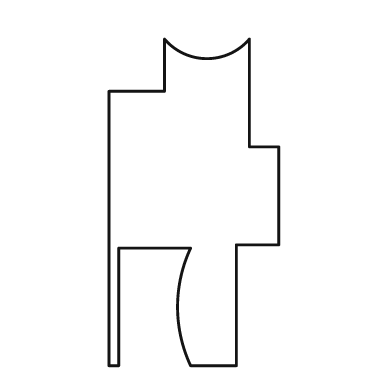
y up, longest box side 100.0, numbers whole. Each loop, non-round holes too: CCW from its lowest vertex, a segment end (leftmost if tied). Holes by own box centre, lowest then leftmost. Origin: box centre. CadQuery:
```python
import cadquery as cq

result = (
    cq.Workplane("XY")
    .moveTo(-26.0, -50.0)
    .lineTo(-23.0, -50.0)
    .lineTo(-23.0, -14.0)
    .lineTo(-1.0, -14.0)
    .threePointArc((-5.0, -32.0), (-1.0, -50.0))
    .lineTo(13.0, -50.0)
    .lineTo(13.0, -13.0)
    .lineTo(26.0, -13.0)
    .lineTo(26.0, 17.0)
    .lineTo(17.0, 17.0)
    .lineTo(17.0, 50.0)
    .threePointArc((4.0, 44.0), (-9.0, 50.0))
    .lineTo(-9.0, 34.0)
    .lineTo(-26.0, 34.0)
    .close()
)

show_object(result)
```